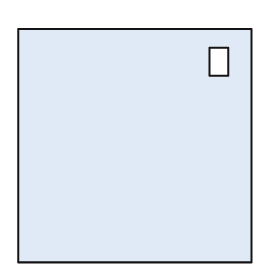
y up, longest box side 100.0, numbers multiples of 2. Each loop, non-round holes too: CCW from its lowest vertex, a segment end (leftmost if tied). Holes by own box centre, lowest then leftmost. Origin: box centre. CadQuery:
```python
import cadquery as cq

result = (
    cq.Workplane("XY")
    .moveTo(-50.0, -50.0)
    .lineTo(50.0, -50.0)
    .lineTo(50.0, 50.0)
    .lineTo(-50.0, 50.0)
    .close()
    .moveTo(32.0, 30.0)
    .lineTo(40.0, 30.0)
    .lineTo(40.0, 42.0)
    .lineTo(32.0, 42.0)
    .close()
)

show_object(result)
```